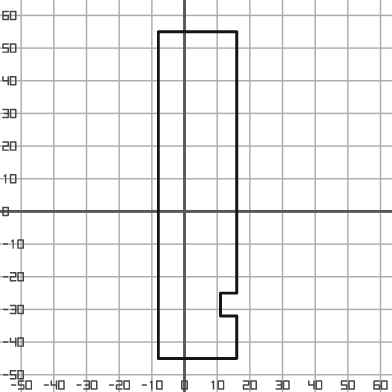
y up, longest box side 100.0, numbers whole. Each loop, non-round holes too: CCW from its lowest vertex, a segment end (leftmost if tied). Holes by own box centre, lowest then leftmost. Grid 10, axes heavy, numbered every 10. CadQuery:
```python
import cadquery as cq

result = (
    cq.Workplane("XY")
    .moveTo(-8.0, -45.0)
    .lineTo(16.0, -45.0)
    .lineTo(16.0, -32.0)
    .lineTo(11.0, -32.0)
    .lineTo(11.0, -25.0)
    .lineTo(16.0, -25.0)
    .lineTo(16.0, 55.0)
    .lineTo(-8.0, 55.0)
    .close()
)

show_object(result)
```